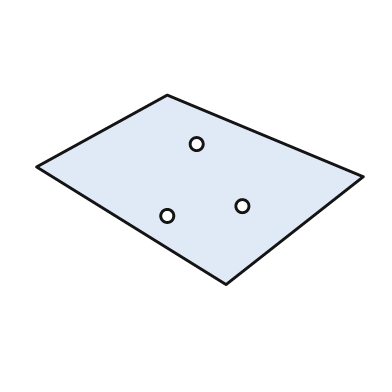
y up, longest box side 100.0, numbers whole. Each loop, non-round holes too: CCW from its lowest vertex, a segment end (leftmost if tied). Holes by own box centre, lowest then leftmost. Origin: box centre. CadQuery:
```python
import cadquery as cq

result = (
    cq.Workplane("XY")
    .moveTo(8.0, -29.0)
    .lineTo(50.0, 4.0)
    .lineTo(-10.0, 29.0)
    .lineTo(-50.0, 7.0)
    .close()
    .moveTo(-10.0, -8.0)
    .circle(2.0)
    .moveTo(13.0, -5.0)
    .circle(2.0)
    .moveTo(-1.0, 14.0)
    .circle(2.0)
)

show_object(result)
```